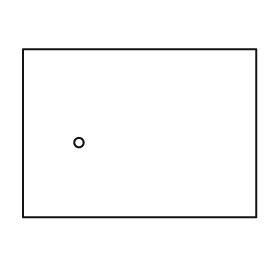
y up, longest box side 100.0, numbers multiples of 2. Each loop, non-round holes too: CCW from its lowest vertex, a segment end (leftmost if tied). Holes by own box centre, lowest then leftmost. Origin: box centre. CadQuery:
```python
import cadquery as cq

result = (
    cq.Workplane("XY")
    .moveTo(-50.0, -36.0)
    .lineTo(50.0, -36.0)
    .lineTo(50.0, 36.0)
    .lineTo(-50.0, 36.0)
    .close()
    .moveTo(-26.0, -4.0)
    .circle(2.0)
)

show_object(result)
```